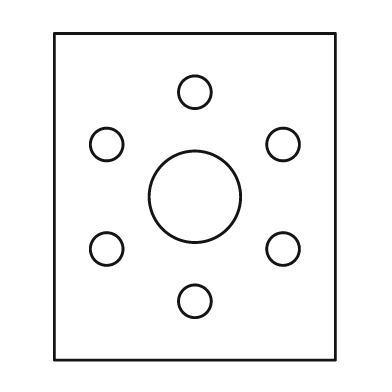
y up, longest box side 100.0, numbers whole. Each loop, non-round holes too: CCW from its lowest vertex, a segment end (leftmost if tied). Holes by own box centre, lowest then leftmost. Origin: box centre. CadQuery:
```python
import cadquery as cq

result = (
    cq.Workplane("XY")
    .moveTo(-43.0, -50.0)
    .lineTo(43.0, -50.0)
    .lineTo(43.0, 50.0)
    .lineTo(-43.0, 50.0)
    .close()
    .moveTo(0.0, -32.0)
    .circle(5.0)
    .moveTo(-27.0, -16.0)
    .circle(5.0)
    .moveTo(27.0, -16.0)
    .circle(5.0)
    .moveTo(0.0, 0.0)
    .circle(14.0)
    .moveTo(-27.0, 16.0)
    .circle(5.0)
    .moveTo(27.0, 16.0)
    .circle(5.0)
    .moveTo(0.0, 32.0)
    .circle(5.0)
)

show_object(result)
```